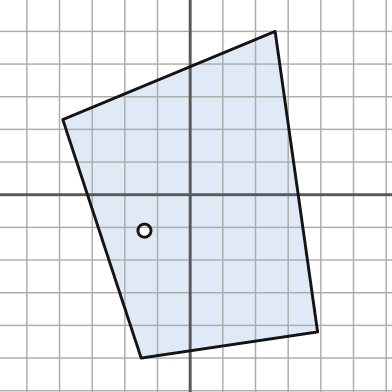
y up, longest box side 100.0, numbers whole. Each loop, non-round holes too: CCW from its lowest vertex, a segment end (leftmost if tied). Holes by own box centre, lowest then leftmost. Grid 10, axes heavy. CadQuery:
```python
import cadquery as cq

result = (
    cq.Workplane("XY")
    .moveTo(-15.0, -50.0)
    .lineTo(39.0, -42.0)
    .lineTo(26.0, 50.0)
    .lineTo(-39.0, 23.0)
    .close()
    .moveTo(-14.0, -11.0)
    .circle(2.0)
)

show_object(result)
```